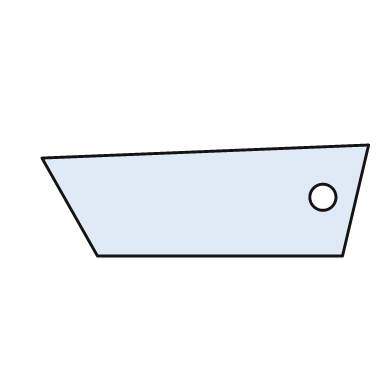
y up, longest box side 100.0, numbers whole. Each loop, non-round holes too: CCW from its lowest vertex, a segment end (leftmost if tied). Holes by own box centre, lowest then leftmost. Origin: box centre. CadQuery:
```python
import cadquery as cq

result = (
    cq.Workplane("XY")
    .moveTo(-33.0, -17.0)
    .lineTo(42.0, -17.0)
    .lineTo(50.0, 17.0)
    .lineTo(-50.0, 13.0)
    .close()
    .moveTo(36.0, 1.0)
    .circle(4.0)
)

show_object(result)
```